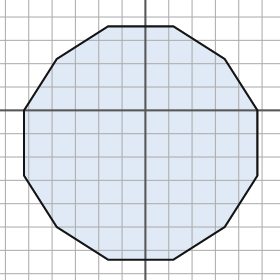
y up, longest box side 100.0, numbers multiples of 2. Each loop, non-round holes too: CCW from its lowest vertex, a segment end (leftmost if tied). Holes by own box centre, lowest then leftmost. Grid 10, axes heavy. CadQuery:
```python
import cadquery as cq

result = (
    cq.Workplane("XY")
    .moveTo(-16.0, -64.0)
    .lineTo(12.0, -64.0)
    .lineTo(34.0, -50.0)
    .lineTo(48.0, -28.0)
    .lineTo(48.0, 0.0)
    .lineTo(34.0, 22.0)
    .lineTo(12.0, 36.0)
    .lineTo(-16.0, 36.0)
    .lineTo(-38.0, 22.0)
    .lineTo(-52.0, 0.0)
    .lineTo(-52.0, -28.0)
    .lineTo(-38.0, -50.0)
    .close()
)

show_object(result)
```